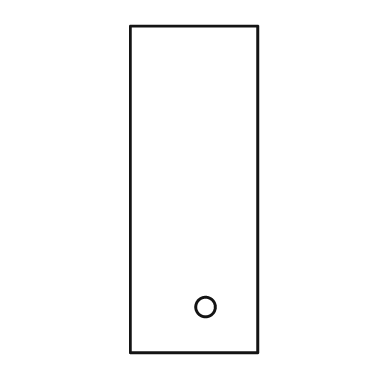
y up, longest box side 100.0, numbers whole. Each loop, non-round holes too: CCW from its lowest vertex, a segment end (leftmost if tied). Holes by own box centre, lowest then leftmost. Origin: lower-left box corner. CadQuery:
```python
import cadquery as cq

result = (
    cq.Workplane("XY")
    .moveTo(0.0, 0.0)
    .lineTo(39.0, 0.0)
    .lineTo(39.0, 100.0)
    .lineTo(0.0, 100.0)
    .close()
    .moveTo(23.0, 14.0)
    .circle(3.0)
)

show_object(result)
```